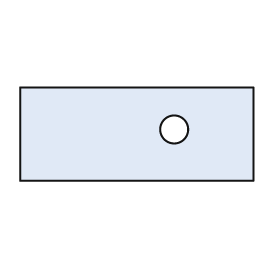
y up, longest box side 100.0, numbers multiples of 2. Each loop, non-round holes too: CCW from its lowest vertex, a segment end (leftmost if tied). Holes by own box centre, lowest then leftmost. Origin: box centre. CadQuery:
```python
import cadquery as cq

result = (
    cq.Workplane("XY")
    .moveTo(-50.0, -20.0)
    .lineTo(50.0, -20.0)
    .lineTo(50.0, 20.0)
    .lineTo(-50.0, 20.0)
    .close()
    .moveTo(16.0, 2.0)
    .circle(6.0)
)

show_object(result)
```